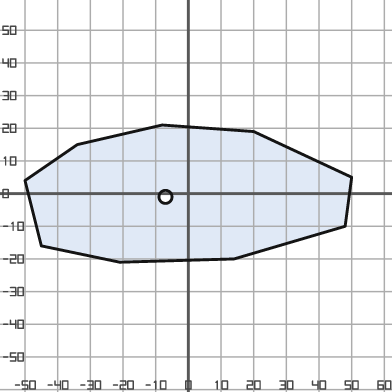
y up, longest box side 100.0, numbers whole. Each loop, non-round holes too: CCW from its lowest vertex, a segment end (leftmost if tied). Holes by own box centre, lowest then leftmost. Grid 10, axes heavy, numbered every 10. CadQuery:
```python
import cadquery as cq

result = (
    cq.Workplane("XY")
    .moveTo(-21.0, -21.0)
    .lineTo(14.0, -20.0)
    .lineTo(48.0, -10.0)
    .lineTo(50.0, 5.0)
    .lineTo(20.0, 19.0)
    .lineTo(-8.0, 21.0)
    .lineTo(-34.0, 15.0)
    .lineTo(-50.0, 4.0)
    .lineTo(-45.0, -16.0)
    .close()
    .moveTo(-7.0, -1.0)
    .circle(2.0)
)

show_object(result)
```